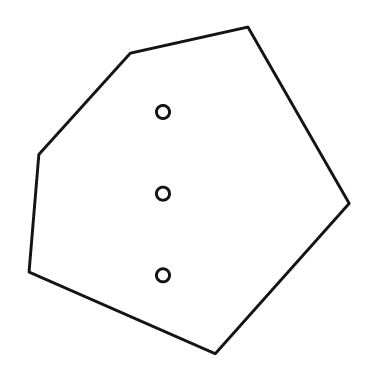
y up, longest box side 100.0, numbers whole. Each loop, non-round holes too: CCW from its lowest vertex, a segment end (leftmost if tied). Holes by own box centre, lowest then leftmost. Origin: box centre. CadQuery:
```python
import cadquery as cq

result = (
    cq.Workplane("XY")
    .moveTo(8.0, -50.0)
    .lineTo(49.0, -4.0)
    .lineTo(18.0, 50.0)
    .lineTo(-18.0, 42.0)
    .lineTo(-46.0, 11.0)
    .lineTo(-49.0, -25.0)
    .close()
    .moveTo(-8.0, -26.0)
    .circle(2.0)
    .moveTo(-8.0, -1.0)
    .circle(2.0)
    .moveTo(-8.0, 24.0)
    .circle(2.0)
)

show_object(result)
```